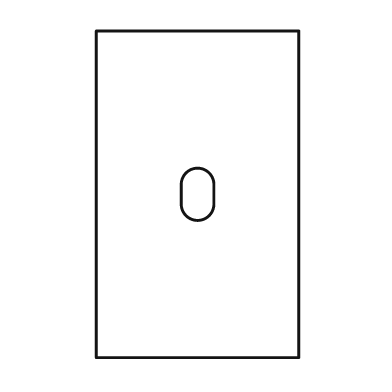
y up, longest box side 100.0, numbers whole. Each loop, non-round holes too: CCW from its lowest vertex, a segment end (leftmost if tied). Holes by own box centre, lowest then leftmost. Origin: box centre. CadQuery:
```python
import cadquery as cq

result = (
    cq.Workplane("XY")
    .moveTo(-31.0, -50.0)
    .lineTo(31.0, -50.0)
    .lineTo(31.0, 50.0)
    .lineTo(-31.0, 50.0)
    .close()
    .moveTo(-5.0, -3.0)
    .threePointArc((0.0, -8.0), (5.0, -3.0))
    .lineTo(5.0, 3.0)
    .threePointArc((0.0, 8.0), (-5.0, 3.0))
    .close()
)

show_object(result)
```